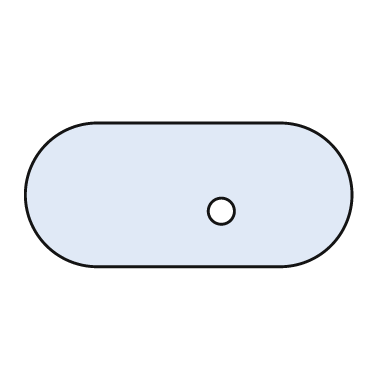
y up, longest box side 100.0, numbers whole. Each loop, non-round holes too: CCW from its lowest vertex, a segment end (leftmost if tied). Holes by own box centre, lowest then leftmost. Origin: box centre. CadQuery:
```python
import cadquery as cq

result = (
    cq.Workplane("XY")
    .moveTo(-28.0, -22.0)
    .lineTo(28.0, -22.0)
    .threePointArc((50.0, 0.0), (28.0, 22.0))
    .lineTo(-28.0, 22.0)
    .threePointArc((-50.0, 0.0), (-28.0, -22.0))
    .close()
    .moveTo(10.0, -5.0)
    .circle(4.0)
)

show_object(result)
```